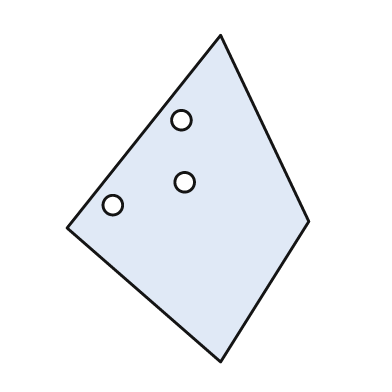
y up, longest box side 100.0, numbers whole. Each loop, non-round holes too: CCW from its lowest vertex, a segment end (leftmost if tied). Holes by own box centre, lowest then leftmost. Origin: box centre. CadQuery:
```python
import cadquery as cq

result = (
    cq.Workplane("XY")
    .moveTo(10.0, -50.0)
    .lineTo(37.0, -7.0)
    .lineTo(10.0, 50.0)
    .lineTo(-37.0, -9.0)
    .close()
    .moveTo(-23.0, -2.0)
    .circle(3.0)
    .moveTo(-1.0, 5.0)
    .circle(3.0)
    .moveTo(-2.0, 24.0)
    .circle(3.0)
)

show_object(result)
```